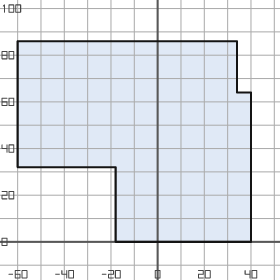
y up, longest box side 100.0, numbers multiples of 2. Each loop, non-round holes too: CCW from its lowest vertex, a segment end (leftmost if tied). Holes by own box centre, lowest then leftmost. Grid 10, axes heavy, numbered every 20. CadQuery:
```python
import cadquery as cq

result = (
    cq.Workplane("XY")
    .moveTo(-18.0, 0.0)
    .lineTo(40.0, 0.0)
    .lineTo(40.0, 64.0)
    .lineTo(34.0, 64.0)
    .lineTo(34.0, 86.0)
    .lineTo(-60.0, 86.0)
    .lineTo(-60.0, 32.0)
    .lineTo(-18.0, 32.0)
    .close()
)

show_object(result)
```